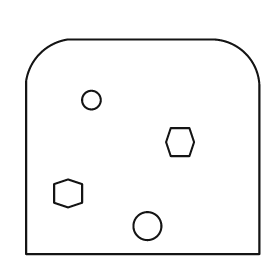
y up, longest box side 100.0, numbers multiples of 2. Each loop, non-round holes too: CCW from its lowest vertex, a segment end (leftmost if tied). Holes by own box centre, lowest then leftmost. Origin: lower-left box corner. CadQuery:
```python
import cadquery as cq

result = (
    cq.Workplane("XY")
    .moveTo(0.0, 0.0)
    .lineTo(100.0, 0.0)
    .lineTo(100.0, 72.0)
    .threePointArc((94.0, 86.0), (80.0, 92.0))
    .lineTo(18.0, 92.0)
    .threePointArc((6.0, 86.0), (0.0, 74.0))
    .close()
    .moveTo(52.0, 12.0)
    .circle(6.0)
    .moveTo(18.0, 20.0)
    .lineTo(24.0, 22.0)
    .lineTo(24.0, 30.0)
    .lineTo(18.0, 32.0)
    .lineTo(12.0, 30.0)
    .lineTo(12.0, 22.0)
    .close()
    .moveTo(62.0, 42.0)
    .lineTo(70.0, 42.0)
    .lineTo(72.0, 48.0)
    .lineTo(70.0, 54.0)
    .lineTo(62.0, 54.0)
    .lineTo(60.0, 48.0)
    .close()
    .moveTo(28.0, 66.0)
    .circle(4.0)
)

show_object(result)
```